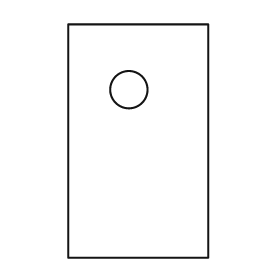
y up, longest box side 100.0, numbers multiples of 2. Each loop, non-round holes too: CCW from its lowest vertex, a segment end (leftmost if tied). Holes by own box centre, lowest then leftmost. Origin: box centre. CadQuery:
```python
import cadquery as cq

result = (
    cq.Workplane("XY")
    .moveTo(-30.0, -50.0)
    .lineTo(30.0, -50.0)
    .lineTo(30.0, 50.0)
    .lineTo(-30.0, 50.0)
    .close()
    .moveTo(-4.0, 22.0)
    .circle(8.0)
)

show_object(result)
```